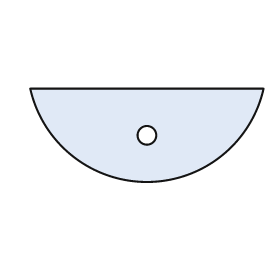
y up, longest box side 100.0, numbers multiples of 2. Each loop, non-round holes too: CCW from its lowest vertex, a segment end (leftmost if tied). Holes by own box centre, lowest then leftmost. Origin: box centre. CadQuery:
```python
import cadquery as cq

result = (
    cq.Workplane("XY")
    .moveTo(-50.0, 20.0)
    .threePointArc((0.0, -20.0), (50.0, 20.0))
    .close()
    .moveTo(0.0, 0.0)
    .circle(4.0)
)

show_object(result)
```